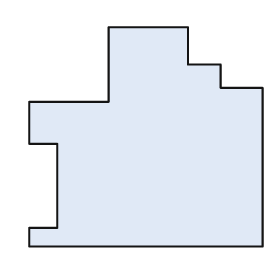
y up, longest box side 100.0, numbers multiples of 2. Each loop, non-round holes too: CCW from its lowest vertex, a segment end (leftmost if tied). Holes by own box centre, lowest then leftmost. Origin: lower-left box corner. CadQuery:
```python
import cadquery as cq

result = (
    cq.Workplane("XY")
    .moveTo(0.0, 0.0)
    .lineTo(100.0, 0.0)
    .lineTo(100.0, 68.0)
    .lineTo(82.0, 68.0)
    .lineTo(82.0, 78.0)
    .lineTo(68.0, 78.0)
    .lineTo(68.0, 94.0)
    .lineTo(34.0, 94.0)
    .lineTo(34.0, 62.0)
    .lineTo(0.0, 62.0)
    .lineTo(0.0, 44.0)
    .lineTo(12.0, 44.0)
    .lineTo(12.0, 8.0)
    .lineTo(0.0, 8.0)
    .close()
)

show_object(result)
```